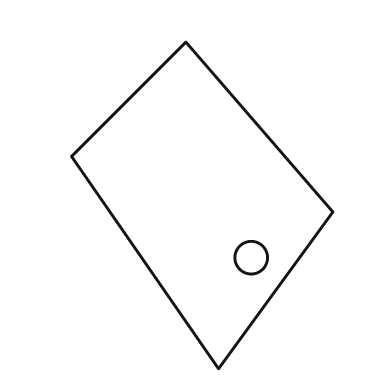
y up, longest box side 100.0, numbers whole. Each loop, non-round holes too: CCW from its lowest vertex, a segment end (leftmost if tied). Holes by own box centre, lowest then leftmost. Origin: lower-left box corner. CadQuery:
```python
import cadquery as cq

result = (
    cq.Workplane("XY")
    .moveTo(45.0, 0.0)
    .lineTo(80.0, 48.0)
    .lineTo(35.0, 100.0)
    .lineTo(0.0, 65.0)
    .close()
    .moveTo(55.0, 34.0)
    .circle(5.0)
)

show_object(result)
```